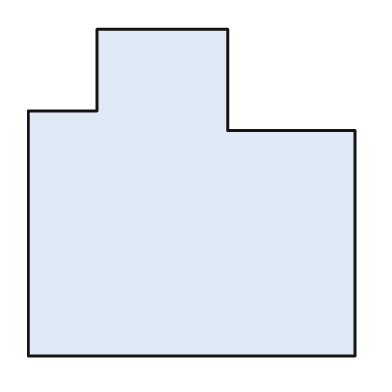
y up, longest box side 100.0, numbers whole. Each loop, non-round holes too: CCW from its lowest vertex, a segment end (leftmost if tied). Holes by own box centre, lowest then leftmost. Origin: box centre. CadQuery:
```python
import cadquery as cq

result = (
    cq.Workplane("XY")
    .moveTo(-50.0, -50.0)
    .lineTo(50.0, -50.0)
    .lineTo(50.0, 19.0)
    .lineTo(11.0, 19.0)
    .lineTo(11.0, 50.0)
    .lineTo(-29.0, 50.0)
    .lineTo(-29.0, 25.0)
    .lineTo(-50.0, 25.0)
    .close()
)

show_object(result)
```